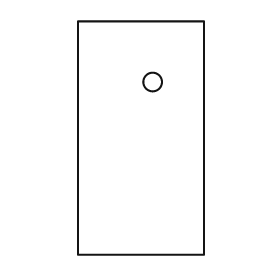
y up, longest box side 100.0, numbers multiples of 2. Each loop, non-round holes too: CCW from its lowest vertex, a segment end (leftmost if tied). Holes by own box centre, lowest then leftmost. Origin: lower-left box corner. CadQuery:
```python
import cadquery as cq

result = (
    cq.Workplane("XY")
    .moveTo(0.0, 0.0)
    .lineTo(54.0, 0.0)
    .lineTo(54.0, 100.0)
    .lineTo(0.0, 100.0)
    .close()
    .moveTo(32.0, 74.0)
    .circle(4.0)
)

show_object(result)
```